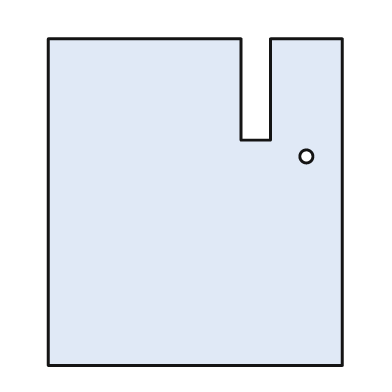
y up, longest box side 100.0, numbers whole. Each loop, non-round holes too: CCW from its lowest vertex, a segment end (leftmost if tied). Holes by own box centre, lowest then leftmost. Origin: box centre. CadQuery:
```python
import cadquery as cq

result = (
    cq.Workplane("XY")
    .moveTo(-45.0, -50.0)
    .lineTo(45.0, -50.0)
    .lineTo(45.0, 50.0)
    .lineTo(23.0, 50.0)
    .lineTo(23.0, 19.0)
    .lineTo(14.0, 19.0)
    .lineTo(14.0, 50.0)
    .lineTo(-45.0, 50.0)
    .close()
    .moveTo(34.0, 14.0)
    .circle(2.0)
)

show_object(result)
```